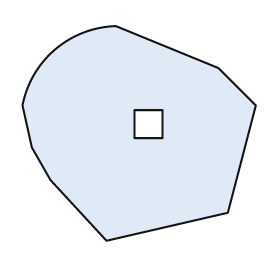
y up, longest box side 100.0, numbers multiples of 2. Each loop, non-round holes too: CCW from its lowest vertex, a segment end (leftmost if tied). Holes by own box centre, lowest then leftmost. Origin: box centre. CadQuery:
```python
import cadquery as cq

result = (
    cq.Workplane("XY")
    .moveTo(-14.0, -46.0)
    .lineTo(38.0, -34.0)
    .lineTo(50.0, 12.0)
    .lineTo(34.0, 28.0)
    .lineTo(-10.0, 46.0)
    .threePointArc((-36.0, 36.0), (-50.0, 12.0))
    .lineTo(-46.0, -6.0)
    .lineTo(-38.0, -20.0)
    .close()
    .moveTo(-2.0, -2.0)
    .lineTo(10.0, -2.0)
    .lineTo(10.0, 10.0)
    .lineTo(-2.0, 10.0)
    .close()
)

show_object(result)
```